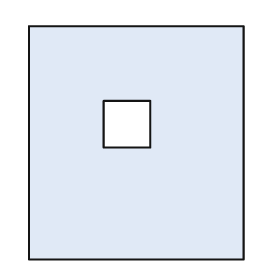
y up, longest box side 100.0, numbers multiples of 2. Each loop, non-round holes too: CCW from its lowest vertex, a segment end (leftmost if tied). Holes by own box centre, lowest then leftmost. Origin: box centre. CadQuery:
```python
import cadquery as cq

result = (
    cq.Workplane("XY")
    .moveTo(-46.0, -50.0)
    .lineTo(46.0, -50.0)
    .lineTo(46.0, 50.0)
    .lineTo(-46.0, 50.0)
    .close()
    .moveTo(-14.0, -2.0)
    .lineTo(6.0, -2.0)
    .lineTo(6.0, 18.0)
    .lineTo(-14.0, 18.0)
    .close()
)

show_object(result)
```